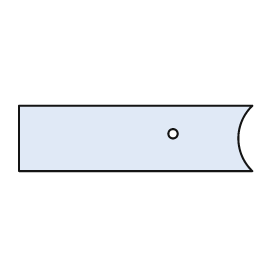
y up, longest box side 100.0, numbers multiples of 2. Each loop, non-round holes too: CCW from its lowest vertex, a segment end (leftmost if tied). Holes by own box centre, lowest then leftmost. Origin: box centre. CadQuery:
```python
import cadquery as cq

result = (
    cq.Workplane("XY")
    .moveTo(-50.0, -14.0)
    .lineTo(50.0, -14.0)
    .threePointArc((44.0, 0.0), (50.0, 14.0))
    .lineTo(-50.0, 14.0)
    .close()
    .moveTo(16.0, 2.0)
    .circle(2.0)
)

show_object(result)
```